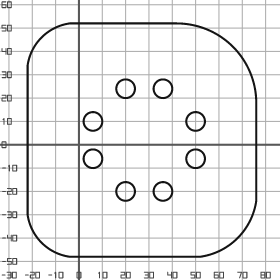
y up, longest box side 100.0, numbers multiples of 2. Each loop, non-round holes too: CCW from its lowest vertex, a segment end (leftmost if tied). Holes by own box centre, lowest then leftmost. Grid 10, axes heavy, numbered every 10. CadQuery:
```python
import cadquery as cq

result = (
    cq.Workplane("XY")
    .moveTo(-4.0, -48.0)
    .lineTo(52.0, -48.0)
    .threePointArc((68.0, -40.0), (76.0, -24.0))
    .lineTo(76.0, 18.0)
    .threePointArc((66.0, 42.0), (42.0, 52.0))
    .lineTo(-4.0, 52.0)
    .threePointArc((-16.0, 46.0), (-22.0, 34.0))
    .lineTo(-22.0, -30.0)
    .threePointArc((-16.0, -42.0), (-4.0, -48.0))
    .close()
    .moveTo(20.0, -20.0)
    .circle(4.0)
    .moveTo(36.0, -20.0)
    .circle(4.0)
    .moveTo(6.0, -6.0)
    .circle(4.0)
    .moveTo(50.0, -6.0)
    .circle(4.0)
    .moveTo(6.0, 10.0)
    .circle(4.0)
    .moveTo(50.0, 10.0)
    .circle(4.0)
    .moveTo(20.0, 24.0)
    .circle(4.0)
    .moveTo(36.0, 24.0)
    .circle(4.0)
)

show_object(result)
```